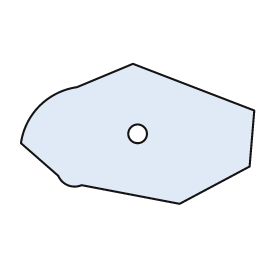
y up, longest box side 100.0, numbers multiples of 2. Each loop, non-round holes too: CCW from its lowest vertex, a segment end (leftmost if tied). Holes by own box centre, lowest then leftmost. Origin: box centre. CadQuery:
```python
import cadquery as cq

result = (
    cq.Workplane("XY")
    .moveTo(18.0, -30.0)
    .lineTo(48.0, -14.0)
    .lineTo(50.0, 10.0)
    .lineTo(-2.0, 30.0)
    .lineTo(-26.0, 20.0)
    .threePointArc((-42.0, 12.0), (-50.0, -4.0))
    .lineTo(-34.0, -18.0)
    .threePointArc((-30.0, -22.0), (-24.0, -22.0))
    .close()
    .moveTo(0.0, 0.0)
    .circle(4.0)
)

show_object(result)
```